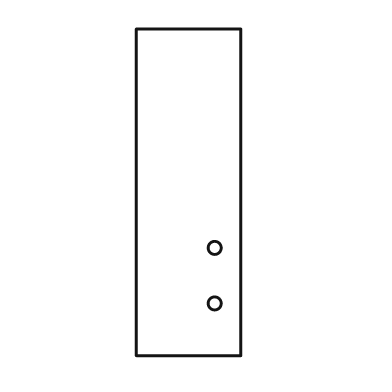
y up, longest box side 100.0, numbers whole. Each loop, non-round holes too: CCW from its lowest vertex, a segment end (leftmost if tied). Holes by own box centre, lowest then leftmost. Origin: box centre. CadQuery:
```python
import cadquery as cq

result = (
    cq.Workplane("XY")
    .moveTo(-16.0, -50.0)
    .lineTo(16.0, -50.0)
    .lineTo(16.0, 50.0)
    .lineTo(-16.0, 50.0)
    .close()
    .moveTo(8.0, -34.0)
    .circle(2.0)
    .moveTo(8.0, -17.0)
    .circle(2.0)
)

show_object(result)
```